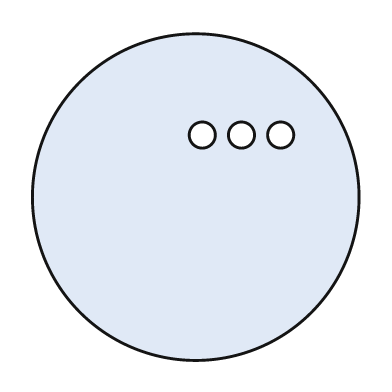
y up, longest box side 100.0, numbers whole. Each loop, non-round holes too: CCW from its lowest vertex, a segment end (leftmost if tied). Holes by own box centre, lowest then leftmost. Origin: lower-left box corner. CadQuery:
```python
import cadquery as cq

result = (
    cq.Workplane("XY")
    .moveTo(50.0, 50.0)
    .circle(50.0)
    .moveTo(52.0, 69.0)
    .circle(4.0)
    .moveTo(64.0, 69.0)
    .circle(4.0)
    .moveTo(76.0, 69.0)
    .circle(4.0)
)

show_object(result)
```